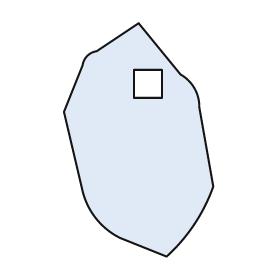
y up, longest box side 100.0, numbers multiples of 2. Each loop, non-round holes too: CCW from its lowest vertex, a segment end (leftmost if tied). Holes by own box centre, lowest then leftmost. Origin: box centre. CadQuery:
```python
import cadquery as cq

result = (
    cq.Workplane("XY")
    .moveTo(12.0, -50.0)
    .threePointArc((24.0, -36.0), (32.0, -20.0))
    .lineTo(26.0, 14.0)
    .threePointArc((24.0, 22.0), (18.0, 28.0))
    .lineTo(0.0, 50.0)
    .lineTo(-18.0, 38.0)
    .threePointArc((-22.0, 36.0), (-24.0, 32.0))
    .lineTo(-32.0, 12.0)
    .lineTo(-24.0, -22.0)
    .threePointArc((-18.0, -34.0), (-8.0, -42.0))
    .close()
    .moveTo(-2.0, 18.0)
    .lineTo(10.0, 18.0)
    .lineTo(10.0, 30.0)
    .lineTo(-2.0, 30.0)
    .close()
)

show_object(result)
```